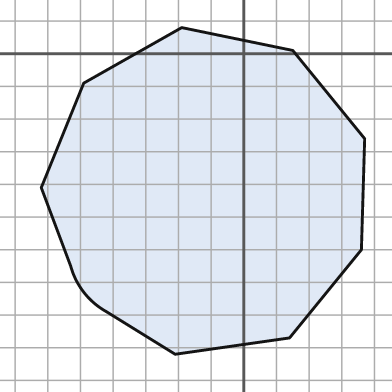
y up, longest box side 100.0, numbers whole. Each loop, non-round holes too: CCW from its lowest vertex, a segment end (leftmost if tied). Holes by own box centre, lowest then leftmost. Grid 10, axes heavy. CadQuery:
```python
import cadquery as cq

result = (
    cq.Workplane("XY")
    .moveTo(-21.0, -92.0)
    .lineTo(14.0, -87.0)
    .lineTo(36.0, -60.0)
    .lineTo(37.0, -26.0)
    .lineTo(15.0, 1.0)
    .lineTo(-19.0, 8.0)
    .lineTo(-49.0, -9.0)
    .lineTo(-62.0, -41.0)
    .lineTo(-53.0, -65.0)
    .threePointArc((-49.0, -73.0), (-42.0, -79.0))
    .close()
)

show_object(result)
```